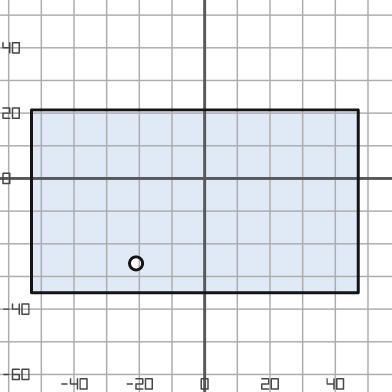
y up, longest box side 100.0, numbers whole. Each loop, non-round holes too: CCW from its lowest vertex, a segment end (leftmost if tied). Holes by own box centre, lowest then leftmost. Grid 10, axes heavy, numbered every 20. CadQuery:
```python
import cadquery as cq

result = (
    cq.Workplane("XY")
    .moveTo(-53.0, -35.0)
    .lineTo(47.0, -35.0)
    .lineTo(47.0, 21.0)
    .lineTo(-53.0, 21.0)
    .close()
    .moveTo(-21.0, -26.0)
    .circle(2.0)
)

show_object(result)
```